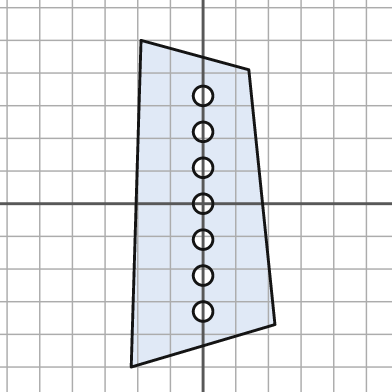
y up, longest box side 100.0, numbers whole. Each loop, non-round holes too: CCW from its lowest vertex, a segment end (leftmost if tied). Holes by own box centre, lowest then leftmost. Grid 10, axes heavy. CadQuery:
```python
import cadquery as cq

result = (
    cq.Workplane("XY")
    .moveTo(-22.0, -50.0)
    .lineTo(22.0, -37.0)
    .lineTo(14.0, 41.0)
    .lineTo(-19.0, 50.0)
    .close()
    .moveTo(0.0, -33.0)
    .circle(3.0)
    .moveTo(0.0, -22.0)
    .circle(3.0)
    .moveTo(0.0, -11.0)
    .circle(3.0)
    .moveTo(0.0, 0.0)
    .circle(3.0)
    .moveTo(0.0, 11.0)
    .circle(3.0)
    .moveTo(0.0, 22.0)
    .circle(3.0)
    .moveTo(0.0, 33.0)
    .circle(3.0)
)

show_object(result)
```